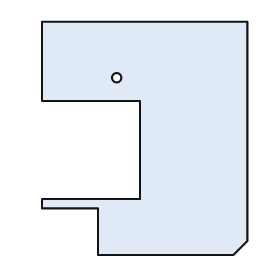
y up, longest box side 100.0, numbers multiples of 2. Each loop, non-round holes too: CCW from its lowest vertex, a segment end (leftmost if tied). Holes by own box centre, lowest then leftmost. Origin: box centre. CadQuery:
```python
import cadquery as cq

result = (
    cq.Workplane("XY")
    .moveTo(-20.0, -50.0)
    .lineTo(38.0, -50.0)
    .lineTo(44.0, -44.0)
    .lineTo(44.0, 50.0)
    .lineTo(-44.0, 50.0)
    .lineTo(-44.0, 16.0)
    .lineTo(-2.0, 16.0)
    .lineTo(-2.0, -26.0)
    .lineTo(-44.0, -26.0)
    .lineTo(-44.0, -30.0)
    .lineTo(-20.0, -30.0)
    .close()
    .moveTo(-12.0, 26.0)
    .circle(2.0)
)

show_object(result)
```